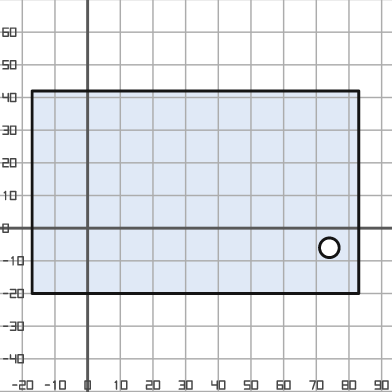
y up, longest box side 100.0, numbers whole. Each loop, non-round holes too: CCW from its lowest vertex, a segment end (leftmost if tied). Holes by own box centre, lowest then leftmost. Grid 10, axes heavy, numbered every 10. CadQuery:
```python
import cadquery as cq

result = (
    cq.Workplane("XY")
    .moveTo(-17.0, -20.0)
    .lineTo(83.0, -20.0)
    .lineTo(83.0, 42.0)
    .lineTo(-17.0, 42.0)
    .close()
    .moveTo(74.0, -6.0)
    .circle(3.0)
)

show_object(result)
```